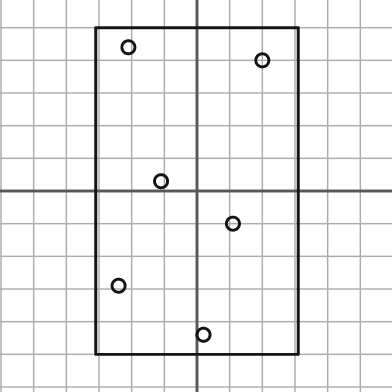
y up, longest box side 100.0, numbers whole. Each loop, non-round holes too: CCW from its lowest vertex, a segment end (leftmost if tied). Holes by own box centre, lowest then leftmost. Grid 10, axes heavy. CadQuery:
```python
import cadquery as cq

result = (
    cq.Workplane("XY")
    .moveTo(-31.0, -50.0)
    .lineTo(31.0, -50.0)
    .lineTo(31.0, 50.0)
    .lineTo(-31.0, 50.0)
    .close()
    .moveTo(2.0, -44.0)
    .circle(2.0)
    .moveTo(-24.0, -29.0)
    .circle(2.0)
    .moveTo(11.0, -10.0)
    .circle(2.0)
    .moveTo(-11.0, 3.0)
    .circle(2.0)
    .moveTo(20.0, 40.0)
    .circle(2.0)
    .moveTo(-21.0, 44.0)
    .circle(2.0)
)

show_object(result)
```